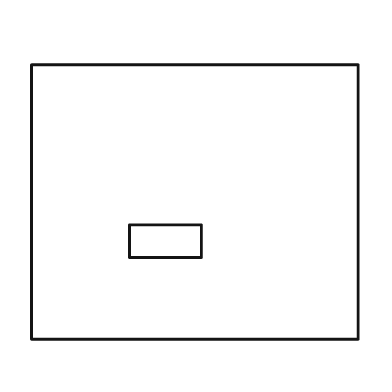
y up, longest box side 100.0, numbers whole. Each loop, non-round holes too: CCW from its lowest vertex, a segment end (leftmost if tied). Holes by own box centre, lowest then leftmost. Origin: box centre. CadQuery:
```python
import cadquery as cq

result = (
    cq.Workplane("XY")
    .moveTo(-50.0, -42.0)
    .lineTo(50.0, -42.0)
    .lineTo(50.0, 42.0)
    .lineTo(-50.0, 42.0)
    .close()
    .moveTo(-20.0, -17.0)
    .lineTo(2.0, -17.0)
    .lineTo(2.0, -7.0)
    .lineTo(-20.0, -7.0)
    .close()
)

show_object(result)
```